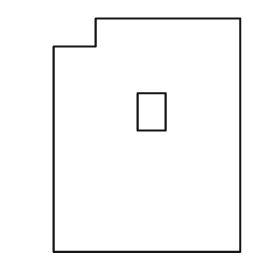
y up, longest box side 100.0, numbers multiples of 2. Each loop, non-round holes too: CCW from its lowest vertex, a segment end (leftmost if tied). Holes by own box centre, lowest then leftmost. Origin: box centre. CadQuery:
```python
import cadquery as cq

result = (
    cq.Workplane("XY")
    .moveTo(-40.0, -50.0)
    .lineTo(40.0, -50.0)
    .lineTo(40.0, 50.0)
    .lineTo(-22.0, 50.0)
    .lineTo(-22.0, 38.0)
    .lineTo(-40.0, 38.0)
    .close()
    .moveTo(-4.0, 2.0)
    .lineTo(8.0, 2.0)
    .lineTo(8.0, 18.0)
    .lineTo(-4.0, 18.0)
    .close()
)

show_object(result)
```